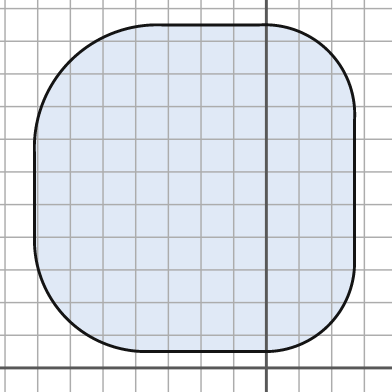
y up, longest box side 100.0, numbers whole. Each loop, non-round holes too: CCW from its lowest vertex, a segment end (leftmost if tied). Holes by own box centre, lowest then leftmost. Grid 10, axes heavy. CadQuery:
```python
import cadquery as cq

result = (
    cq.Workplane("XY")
    .moveTo(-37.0, 5.0)
    .lineTo(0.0, 5.0)
    .threePointArc((19.0, 13.0), (27.0, 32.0))
    .lineTo(27.0, 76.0)
    .threePointArc((19.0, 97.0), (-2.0, 105.0))
    .lineTo(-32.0, 105.0)
    .threePointArc((-60.0, 94.0), (-71.0, 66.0))
    .lineTo(-71.0, 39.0)
    .threePointArc((-61.0, 15.0), (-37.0, 5.0))
    .close()
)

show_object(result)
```